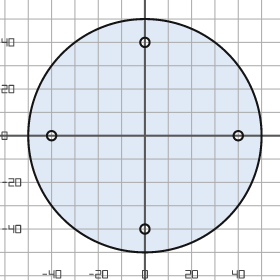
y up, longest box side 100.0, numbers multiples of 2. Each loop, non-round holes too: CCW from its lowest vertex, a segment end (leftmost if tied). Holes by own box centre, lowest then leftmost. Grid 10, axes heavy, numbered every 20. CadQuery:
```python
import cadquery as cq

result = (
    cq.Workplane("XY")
    .moveTo(0.0, 0.0)
    .circle(50.0)
    .moveTo(0.0, -40.0)
    .circle(2.0)
    .moveTo(-40.0, 0.0)
    .circle(2.0)
    .moveTo(40.0, 0.0)
    .circle(2.0)
    .moveTo(0.0, 40.0)
    .circle(2.0)
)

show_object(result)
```